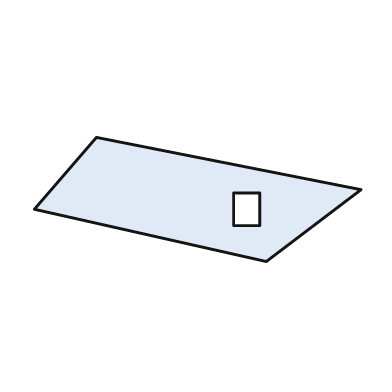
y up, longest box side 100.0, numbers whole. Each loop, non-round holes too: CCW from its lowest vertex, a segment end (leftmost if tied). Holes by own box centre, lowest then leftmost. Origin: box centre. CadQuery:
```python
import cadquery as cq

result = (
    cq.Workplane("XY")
    .moveTo(21.0, -19.0)
    .lineTo(50.0, 3.0)
    .lineTo(-31.0, 19.0)
    .lineTo(-50.0, -3.0)
    .close()
    .moveTo(11.0, -8.0)
    .lineTo(19.0, -8.0)
    .lineTo(19.0, 2.0)
    .lineTo(11.0, 2.0)
    .close()
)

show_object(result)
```